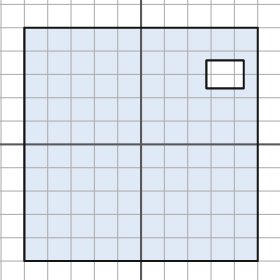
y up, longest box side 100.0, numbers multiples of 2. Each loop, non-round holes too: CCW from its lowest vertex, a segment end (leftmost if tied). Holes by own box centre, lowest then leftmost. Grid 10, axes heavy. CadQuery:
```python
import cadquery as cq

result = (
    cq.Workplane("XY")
    .moveTo(-50.0, -50.0)
    .lineTo(50.0, -50.0)
    .lineTo(50.0, 50.0)
    .lineTo(-50.0, 50.0)
    .close()
    .moveTo(28.0, 24.0)
    .lineTo(44.0, 24.0)
    .lineTo(44.0, 36.0)
    .lineTo(28.0, 36.0)
    .close()
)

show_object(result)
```